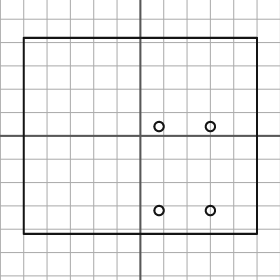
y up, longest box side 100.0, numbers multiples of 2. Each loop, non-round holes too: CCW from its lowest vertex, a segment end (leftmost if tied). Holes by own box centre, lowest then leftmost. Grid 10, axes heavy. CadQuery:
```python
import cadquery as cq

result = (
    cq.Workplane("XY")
    .moveTo(-50.0, -42.0)
    .lineTo(50.0, -42.0)
    .lineTo(50.0, 42.0)
    .lineTo(-50.0, 42.0)
    .close()
    .moveTo(8.0, -32.0)
    .circle(2.0)
    .moveTo(30.0, -32.0)
    .circle(2.0)
    .moveTo(8.0, 4.0)
    .circle(2.0)
    .moveTo(30.0, 4.0)
    .circle(2.0)
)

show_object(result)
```